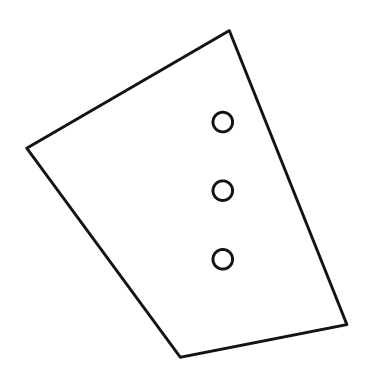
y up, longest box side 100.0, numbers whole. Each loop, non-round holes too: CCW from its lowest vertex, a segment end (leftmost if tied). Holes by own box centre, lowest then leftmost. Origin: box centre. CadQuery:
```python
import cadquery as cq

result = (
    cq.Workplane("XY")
    .moveTo(-2.0, -50.0)
    .lineTo(49.0, -40.0)
    .lineTo(13.0, 50.0)
    .lineTo(-49.0, 14.0)
    .close()
    .moveTo(11.0, -20.0)
    .circle(3.0)
    .moveTo(11.0, 1.0)
    .circle(3.0)
    .moveTo(11.0, 22.0)
    .circle(3.0)
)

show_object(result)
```